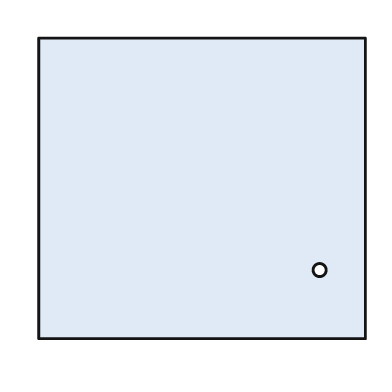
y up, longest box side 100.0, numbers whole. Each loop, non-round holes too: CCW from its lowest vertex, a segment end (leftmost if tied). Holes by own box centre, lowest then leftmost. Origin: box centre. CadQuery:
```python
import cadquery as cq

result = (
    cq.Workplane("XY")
    .moveTo(-50.0, -46.0)
    .lineTo(50.0, -46.0)
    .lineTo(50.0, 46.0)
    .lineTo(-50.0, 46.0)
    .close()
    .moveTo(36.0, -25.0)
    .circle(2.0)
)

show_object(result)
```